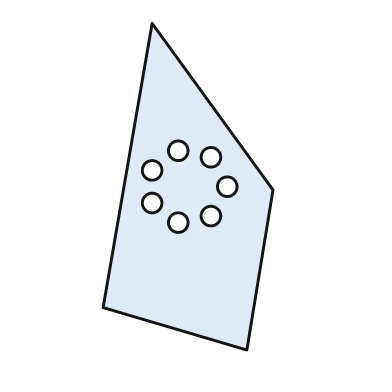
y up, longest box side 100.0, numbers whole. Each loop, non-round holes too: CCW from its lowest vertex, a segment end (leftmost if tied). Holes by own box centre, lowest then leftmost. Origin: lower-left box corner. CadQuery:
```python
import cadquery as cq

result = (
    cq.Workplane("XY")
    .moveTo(44.0, 0.0)
    .lineTo(52.0, 49.0)
    .lineTo(15.0, 100.0)
    .lineTo(0.0, 13.0)
    .close()
    .moveTo(23.0, 39.0)
    .circle(3.0)
    .moveTo(33.0, 41.0)
    .circle(3.0)
    .moveTo(15.0, 45.0)
    .circle(3.0)
    .moveTo(38.0, 50.0)
    .circle(3.0)
    .moveTo(15.0, 55.0)
    .circle(3.0)
    .moveTo(33.0, 59.0)
    .circle(3.0)
    .moveTo(23.0, 61.0)
    .circle(3.0)
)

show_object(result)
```